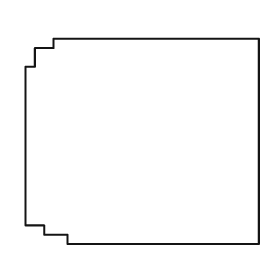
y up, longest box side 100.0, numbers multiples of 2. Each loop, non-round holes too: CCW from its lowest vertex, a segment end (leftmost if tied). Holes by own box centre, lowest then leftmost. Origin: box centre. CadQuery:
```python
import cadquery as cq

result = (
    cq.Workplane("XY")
    .moveTo(-32.0, -44.0)
    .lineTo(50.0, -44.0)
    .lineTo(50.0, 44.0)
    .lineTo(-38.0, 44.0)
    .lineTo(-38.0, 40.0)
    .lineTo(-46.0, 40.0)
    .lineTo(-46.0, 32.0)
    .lineTo(-50.0, 32.0)
    .lineTo(-50.0, -36.0)
    .lineTo(-42.0, -36.0)
    .lineTo(-42.0, -40.0)
    .lineTo(-32.0, -40.0)
    .close()
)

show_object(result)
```